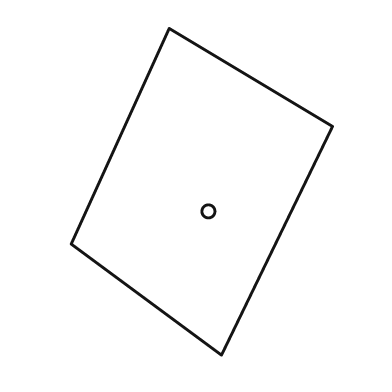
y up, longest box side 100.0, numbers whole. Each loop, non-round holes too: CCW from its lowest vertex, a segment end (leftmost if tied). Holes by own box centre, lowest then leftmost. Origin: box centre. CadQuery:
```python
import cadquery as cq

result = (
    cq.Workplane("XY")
    .moveTo(6.0, -50.0)
    .lineTo(40.0, 20.0)
    .lineTo(-10.0, 50.0)
    .lineTo(-40.0, -16.0)
    .close()
    .moveTo(2.0, -6.0)
    .circle(2.0)
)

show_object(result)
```